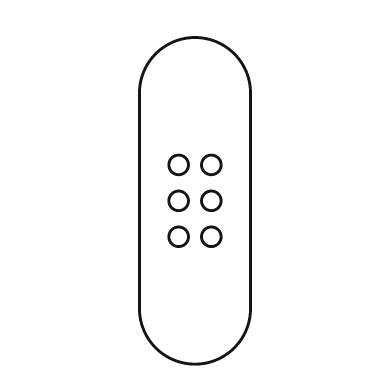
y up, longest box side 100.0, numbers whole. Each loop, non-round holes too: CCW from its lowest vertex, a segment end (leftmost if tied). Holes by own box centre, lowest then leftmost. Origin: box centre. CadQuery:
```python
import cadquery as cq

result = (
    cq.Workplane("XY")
    .moveTo(-17.0, -33.0)
    .threePointArc((0.0, -50.0), (17.0, -33.0))
    .lineTo(17.0, 33.0)
    .threePointArc((0.0, 50.0), (-17.0, 33.0))
    .close()
    .moveTo(-5.0, -11.0)
    .circle(3.0)
    .moveTo(5.0, -11.0)
    .circle(3.0)
    .moveTo(-5.0, 0.0)
    .circle(3.0)
    .moveTo(5.0, 0.0)
    .circle(3.0)
    .moveTo(-5.0, 11.0)
    .circle(3.0)
    .moveTo(5.0, 11.0)
    .circle(3.0)
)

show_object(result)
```